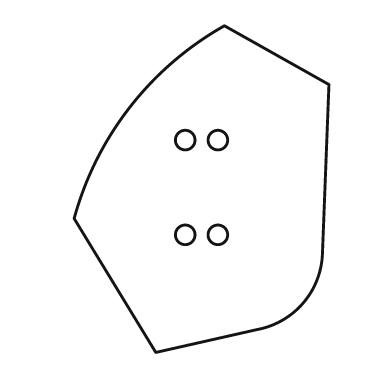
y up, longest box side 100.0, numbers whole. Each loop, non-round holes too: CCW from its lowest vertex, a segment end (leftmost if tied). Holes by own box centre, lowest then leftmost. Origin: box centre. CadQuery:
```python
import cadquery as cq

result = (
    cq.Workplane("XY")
    .moveTo(-14.0, -50.0)
    .lineTo(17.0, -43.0)
    .threePointArc((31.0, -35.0), (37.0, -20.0))
    .lineTo(39.0, 32.0)
    .lineTo(7.0, 50.0)
    .threePointArc((-22.0, 25.0), (-39.0, -9.0))
    .close()
    .moveTo(-5.0, -14.0)
    .circle(3.0)
    .moveTo(5.0, -14.0)
    .circle(3.0)
    .moveTo(-5.0, 15.0)
    .circle(3.0)
    .moveTo(5.0, 15.0)
    .circle(3.0)
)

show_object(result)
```